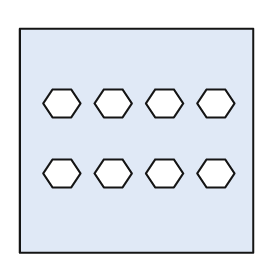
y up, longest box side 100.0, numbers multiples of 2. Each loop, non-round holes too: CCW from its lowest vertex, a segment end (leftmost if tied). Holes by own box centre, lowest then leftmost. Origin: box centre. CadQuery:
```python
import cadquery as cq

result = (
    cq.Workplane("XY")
    .moveTo(-50.0, -48.0)
    .lineTo(50.0, -48.0)
    .lineTo(50.0, 48.0)
    .lineTo(-50.0, 48.0)
    .close()
    .moveTo(-36.0, -20.0)
    .lineTo(-28.0, -20.0)
    .lineTo(-24.0, -14.0)
    .lineTo(-28.0, -8.0)
    .lineTo(-36.0, -8.0)
    .lineTo(-40.0, -14.0)
    .close()
    .moveTo(-14.0, -20.0)
    .lineTo(-6.0, -20.0)
    .lineTo(-2.0, -14.0)
    .lineTo(-6.0, -8.0)
    .lineTo(-14.0, -8.0)
    .lineTo(-18.0, -14.0)
    .close()
    .moveTo(8.0, -20.0)
    .lineTo(16.0, -20.0)
    .lineTo(20.0, -14.0)
    .lineTo(16.0, -8.0)
    .lineTo(8.0, -8.0)
    .lineTo(4.0, -14.0)
    .close()
    .moveTo(30.0, -20.0)
    .lineTo(38.0, -20.0)
    .lineTo(42.0, -14.0)
    .lineTo(38.0, -8.0)
    .lineTo(30.0, -8.0)
    .lineTo(26.0, -14.0)
    .close()
    .moveTo(-36.0, 10.0)
    .lineTo(-28.0, 10.0)
    .lineTo(-24.0, 16.0)
    .lineTo(-28.0, 22.0)
    .lineTo(-36.0, 22.0)
    .lineTo(-40.0, 16.0)
    .close()
    .moveTo(-14.0, 10.0)
    .lineTo(-6.0, 10.0)
    .lineTo(-2.0, 16.0)
    .lineTo(-6.0, 22.0)
    .lineTo(-14.0, 22.0)
    .lineTo(-18.0, 16.0)
    .close()
    .moveTo(8.0, 10.0)
    .lineTo(16.0, 10.0)
    .lineTo(20.0, 16.0)
    .lineTo(16.0, 22.0)
    .lineTo(8.0, 22.0)
    .lineTo(4.0, 16.0)
    .close()
    .moveTo(30.0, 10.0)
    .lineTo(38.0, 10.0)
    .lineTo(42.0, 16.0)
    .lineTo(38.0, 22.0)
    .lineTo(30.0, 22.0)
    .lineTo(26.0, 16.0)
    .close()
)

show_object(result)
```